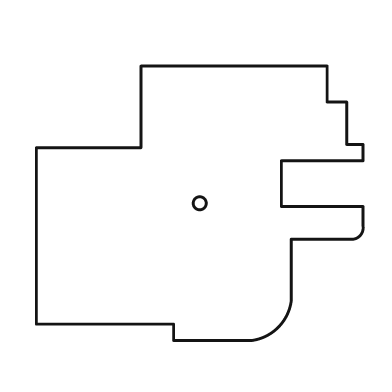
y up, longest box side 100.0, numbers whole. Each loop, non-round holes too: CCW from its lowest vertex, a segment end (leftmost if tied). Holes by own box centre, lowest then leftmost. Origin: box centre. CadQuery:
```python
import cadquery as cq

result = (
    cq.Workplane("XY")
    .moveTo(-8.0, -42.0)
    .lineTo(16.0, -42.0)
    .threePointArc((24.0, -38.0), (28.0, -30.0))
    .lineTo(28.0, -11.0)
    .lineTo(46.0, -11.0)
    .threePointArc((49.0, -10.0), (50.0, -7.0))
    .lineTo(50.0, -1.0)
    .lineTo(25.0, -1.0)
    .lineTo(25.0, 13.0)
    .lineTo(50.0, 13.0)
    .lineTo(50.0, 18.0)
    .lineTo(45.0, 18.0)
    .lineTo(45.0, 31.0)
    .lineTo(39.0, 31.0)
    .lineTo(39.0, 42.0)
    .lineTo(-18.0, 42.0)
    .lineTo(-18.0, 17.0)
    .lineTo(-50.0, 17.0)
    .lineTo(-50.0, -37.0)
    .lineTo(-8.0, -37.0)
    .close()
    .moveTo(0.0, 0.0)
    .circle(2.0)
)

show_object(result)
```